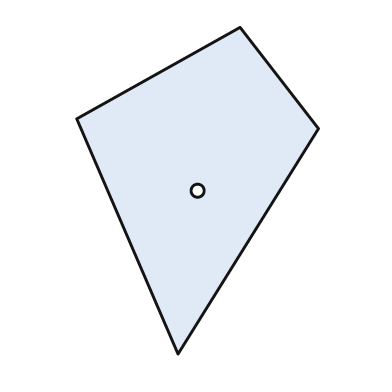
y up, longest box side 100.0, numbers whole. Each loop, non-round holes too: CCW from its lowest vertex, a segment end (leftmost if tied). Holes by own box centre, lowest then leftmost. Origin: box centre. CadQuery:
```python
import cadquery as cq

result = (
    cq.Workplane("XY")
    .moveTo(-6.0, -50.0)
    .lineTo(37.0, 19.0)
    .lineTo(13.0, 50.0)
    .lineTo(-37.0, 22.0)
    .close()
    .moveTo(0.0, 0.0)
    .circle(2.0)
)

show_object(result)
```